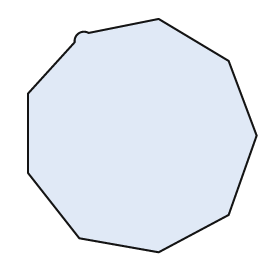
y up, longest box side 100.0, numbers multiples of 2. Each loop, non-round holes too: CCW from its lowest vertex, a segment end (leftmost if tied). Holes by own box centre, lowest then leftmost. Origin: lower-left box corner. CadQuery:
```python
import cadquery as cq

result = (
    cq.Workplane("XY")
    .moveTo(56.0, 0.0)
    .lineTo(86.0, 16.0)
    .lineTo(98.0, 50.0)
    .lineTo(86.0, 82.0)
    .lineTo(56.0, 100.0)
    .lineTo(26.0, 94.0)
    .threePointArc((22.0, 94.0), (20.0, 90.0))
    .lineTo(0.0, 68.0)
    .lineTo(0.0, 34.0)
    .lineTo(22.0, 6.0)
    .close()
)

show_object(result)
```